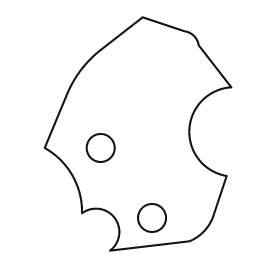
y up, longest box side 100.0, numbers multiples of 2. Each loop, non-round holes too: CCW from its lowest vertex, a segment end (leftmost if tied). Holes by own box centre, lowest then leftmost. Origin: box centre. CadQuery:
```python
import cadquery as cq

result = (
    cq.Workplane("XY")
    .moveTo(-12.0, -50.0)
    .lineTo(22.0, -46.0)
    .threePointArc((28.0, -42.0), (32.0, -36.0))
    .lineTo(38.0, -18.0)
    .threePointArc((22.0, 2.0), (40.0, 20.0))
    .lineTo(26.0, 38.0)
    .threePointArc((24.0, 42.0), (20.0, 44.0))
    .lineTo(2.0, 50.0)
    .lineTo(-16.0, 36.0)
    .threePointArc((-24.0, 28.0), (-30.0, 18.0))
    .lineTo(-40.0, -6.0)
    .threePointArc((-28.0, -18.0), (-24.0, -34.0))
    .threePointArc((-10.0, -36.0), (-12.0, -50.0))
    .close()
    .moveTo(6.0, -36.0)
    .circle(6.0)
    .moveTo(-16.0, -6.0)
    .circle(6.0)
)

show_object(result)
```